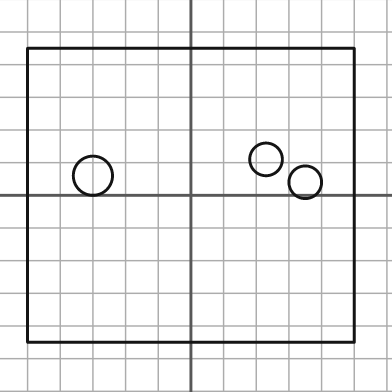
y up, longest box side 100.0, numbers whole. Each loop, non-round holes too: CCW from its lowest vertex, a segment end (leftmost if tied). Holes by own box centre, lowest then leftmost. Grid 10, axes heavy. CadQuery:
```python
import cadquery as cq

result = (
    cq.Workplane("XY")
    .moveTo(-50.0, -45.0)
    .lineTo(50.0, -45.0)
    .lineTo(50.0, 45.0)
    .lineTo(-50.0, 45.0)
    .close()
    .moveTo(35.0, 4.0)
    .circle(5.0)
    .moveTo(-30.0, 6.0)
    .circle(6.0)
    .moveTo(23.0, 11.0)
    .circle(5.0)
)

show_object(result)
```